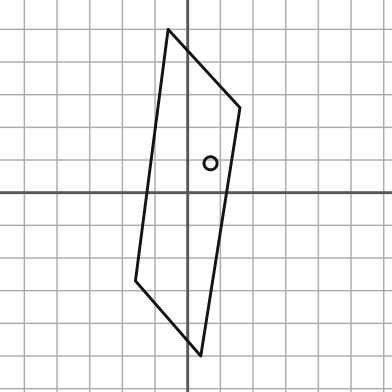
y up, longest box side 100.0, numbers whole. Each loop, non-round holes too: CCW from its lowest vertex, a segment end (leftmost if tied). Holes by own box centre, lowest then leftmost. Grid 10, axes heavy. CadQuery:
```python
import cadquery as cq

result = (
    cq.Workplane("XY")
    .moveTo(4.0, -50.0)
    .lineTo(16.0, 26.0)
    .lineTo(-6.0, 50.0)
    .lineTo(-16.0, -27.0)
    .close()
    .moveTo(7.0, 9.0)
    .circle(2.0)
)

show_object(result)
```